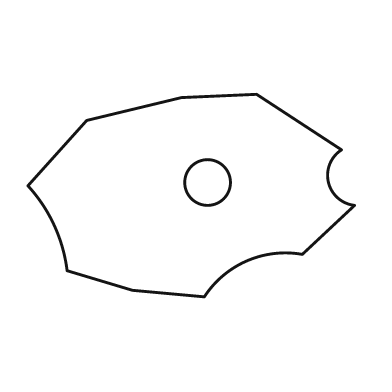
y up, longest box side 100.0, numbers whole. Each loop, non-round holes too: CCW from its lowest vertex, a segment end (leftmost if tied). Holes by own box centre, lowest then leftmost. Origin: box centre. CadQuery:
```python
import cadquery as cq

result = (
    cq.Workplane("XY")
    .moveTo(4.0, -31.0)
    .threePointArc((17.0, -20.0), (34.0, -18.0))
    .lineTo(50.0, -3.0)
    .threePointArc((42.0, 4.0), (46.0, 14.0))
    .lineTo(20.0, 31.0)
    .lineTo(-3.0, 30.0)
    .lineTo(-32.0, 23.0)
    .lineTo(-50.0, 3.0)
    .threePointArc((-42.0, -9.0), (-38.0, -23.0))
    .lineTo(-18.0, -29.0)
    .close()
    .moveTo(5.0, 4.0)
    .circle(7.0)
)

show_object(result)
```